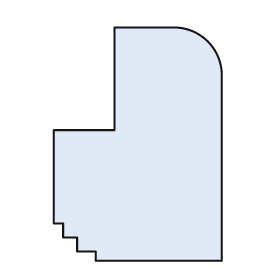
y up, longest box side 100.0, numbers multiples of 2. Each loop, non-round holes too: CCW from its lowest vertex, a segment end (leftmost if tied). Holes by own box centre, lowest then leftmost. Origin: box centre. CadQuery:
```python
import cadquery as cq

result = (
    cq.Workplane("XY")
    .moveTo(-18.0, -50.0)
    .lineTo(36.0, -50.0)
    .lineTo(36.0, 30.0)
    .threePointArc((30.0, 44.0), (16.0, 50.0))
    .lineTo(-10.0, 50.0)
    .lineTo(-10.0, 6.0)
    .lineTo(-36.0, 6.0)
    .lineTo(-36.0, -34.0)
    .lineTo(-32.0, -34.0)
    .lineTo(-32.0, -40.0)
    .lineTo(-26.0, -40.0)
    .lineTo(-26.0, -46.0)
    .lineTo(-18.0, -46.0)
    .close()
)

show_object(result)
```